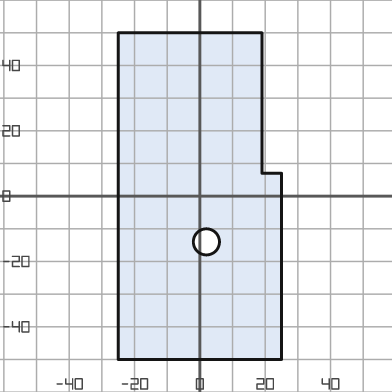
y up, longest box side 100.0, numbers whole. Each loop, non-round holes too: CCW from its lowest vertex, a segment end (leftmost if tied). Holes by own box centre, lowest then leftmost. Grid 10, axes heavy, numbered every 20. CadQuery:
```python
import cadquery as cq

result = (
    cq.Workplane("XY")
    .moveTo(-25.0, -50.0)
    .lineTo(25.0, -50.0)
    .lineTo(25.0, 7.0)
    .lineTo(19.0, 7.0)
    .lineTo(19.0, 50.0)
    .lineTo(-25.0, 50.0)
    .close()
    .moveTo(2.0, -14.0)
    .circle(4.0)
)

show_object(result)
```